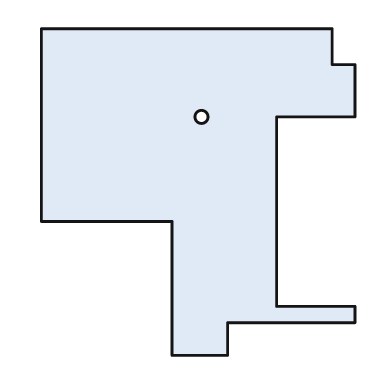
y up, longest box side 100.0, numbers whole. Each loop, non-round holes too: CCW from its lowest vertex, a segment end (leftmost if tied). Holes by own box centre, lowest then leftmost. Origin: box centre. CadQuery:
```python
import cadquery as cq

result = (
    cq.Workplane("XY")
    .moveTo(-8.0, -50.0)
    .lineTo(9.0, -50.0)
    .lineTo(9.0, -40.0)
    .lineTo(48.0, -40.0)
    .lineTo(48.0, -35.0)
    .lineTo(24.0, -35.0)
    .lineTo(24.0, 23.0)
    .lineTo(48.0, 23.0)
    .lineTo(48.0, 39.0)
    .lineTo(41.0, 39.0)
    .lineTo(41.0, 50.0)
    .lineTo(-48.0, 50.0)
    .lineTo(-48.0, -9.0)
    .lineTo(-8.0, -9.0)
    .close()
    .moveTo(1.0, 23.0)
    .circle(2.0)
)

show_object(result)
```